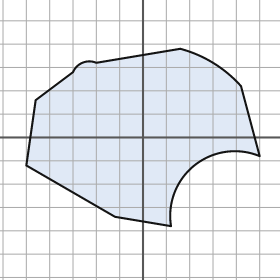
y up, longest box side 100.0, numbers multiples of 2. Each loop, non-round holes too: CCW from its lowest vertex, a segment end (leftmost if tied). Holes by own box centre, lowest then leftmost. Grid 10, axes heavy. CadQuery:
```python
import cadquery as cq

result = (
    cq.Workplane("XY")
    .moveTo(12.0, -38.0)
    .threePointArc((22.0, -12.0), (50.0, -8.0))
    .lineTo(42.0, 22.0)
    .threePointArc((30.0, 32.0), (16.0, 38.0))
    .lineTo(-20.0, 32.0)
    .threePointArc((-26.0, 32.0), (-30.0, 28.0))
    .lineTo(-46.0, 16.0)
    .lineTo(-50.0, -12.0)
    .lineTo(-12.0, -34.0)
    .close()
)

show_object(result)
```